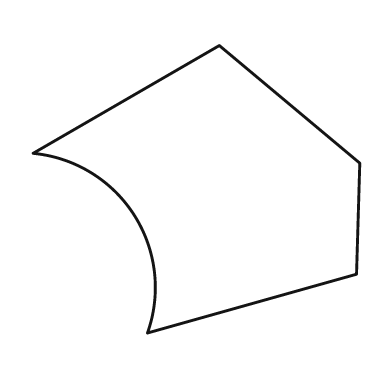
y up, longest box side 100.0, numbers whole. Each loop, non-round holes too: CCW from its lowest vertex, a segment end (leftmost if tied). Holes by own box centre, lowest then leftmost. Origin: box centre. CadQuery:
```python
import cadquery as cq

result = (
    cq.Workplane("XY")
    .moveTo(-15.0, -44.0)
    .lineTo(49.0, -26.0)
    .lineTo(50.0, 8.0)
    .lineTo(7.0, 44.0)
    .lineTo(-50.0, 11.0)
    .threePointArc((-19.0, -8.0), (-15.0, -44.0))
    .close()
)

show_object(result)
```